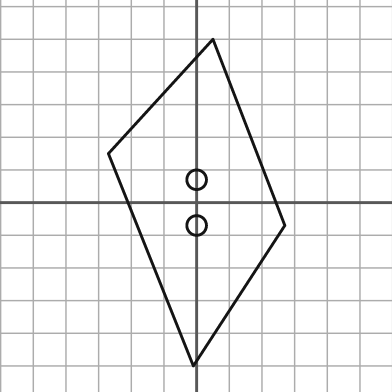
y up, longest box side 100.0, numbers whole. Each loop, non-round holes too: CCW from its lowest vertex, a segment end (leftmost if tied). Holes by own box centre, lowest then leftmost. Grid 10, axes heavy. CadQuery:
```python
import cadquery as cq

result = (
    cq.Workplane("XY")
    .moveTo(-1.0, -50.0)
    .lineTo(27.0, -7.0)
    .lineTo(5.0, 50.0)
    .lineTo(-27.0, 15.0)
    .close()
    .moveTo(0.0, -7.0)
    .circle(3.0)
    .moveTo(0.0, 7.0)
    .circle(3.0)
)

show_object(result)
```